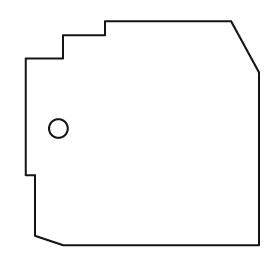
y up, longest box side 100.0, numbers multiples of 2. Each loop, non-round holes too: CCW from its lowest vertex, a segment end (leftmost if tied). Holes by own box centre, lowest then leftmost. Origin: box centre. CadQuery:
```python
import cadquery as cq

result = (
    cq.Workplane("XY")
    .moveTo(-34.0, -48.0)
    .lineTo(50.0, -48.0)
    .lineTo(50.0, 26.0)
    .lineTo(38.0, 48.0)
    .lineTo(-16.0, 48.0)
    .lineTo(-16.0, 42.0)
    .lineTo(-34.0, 42.0)
    .lineTo(-34.0, 32.0)
    .lineTo(-50.0, 32.0)
    .lineTo(-50.0, -18.0)
    .lineTo(-46.0, -18.0)
    .lineTo(-46.0, -44.0)
    .close()
    .moveTo(-36.0, 2.0)
    .circle(4.0)
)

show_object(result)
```